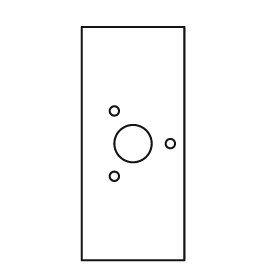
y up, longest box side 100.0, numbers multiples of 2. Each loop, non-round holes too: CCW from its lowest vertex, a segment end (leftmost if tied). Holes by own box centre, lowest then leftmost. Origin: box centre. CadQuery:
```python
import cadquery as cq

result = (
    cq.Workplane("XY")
    .moveTo(-22.0, -50.0)
    .lineTo(22.0, -50.0)
    .lineTo(22.0, 50.0)
    .lineTo(-22.0, 50.0)
    .close()
    .moveTo(-8.0, -14.0)
    .circle(2.0)
    .moveTo(0.0, 0.0)
    .circle(8.0)
    .moveTo(16.0, 0.0)
    .circle(2.0)
    .moveTo(-8.0, 14.0)
    .circle(2.0)
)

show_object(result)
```